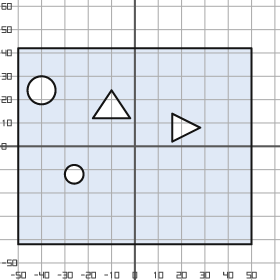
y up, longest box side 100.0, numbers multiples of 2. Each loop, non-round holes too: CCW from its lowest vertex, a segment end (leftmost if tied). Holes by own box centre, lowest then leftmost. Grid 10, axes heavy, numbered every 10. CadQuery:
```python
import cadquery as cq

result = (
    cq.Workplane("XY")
    .moveTo(-50.0, -42.0)
    .lineTo(50.0, -42.0)
    .lineTo(50.0, 42.0)
    .lineTo(-50.0, 42.0)
    .close()
    .moveTo(-26.0, -12.0)
    .circle(4.0)
    .moveTo(16.0, 2.0)
    .lineTo(28.0, 8.0)
    .lineTo(16.0, 14.0)
    .close()
    .moveTo(-18.0, 12.0)
    .lineTo(-2.0, 12.0)
    .lineTo(-10.0, 24.0)
    .close()
    .moveTo(-40.0, 24.0)
    .circle(6.0)
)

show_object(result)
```